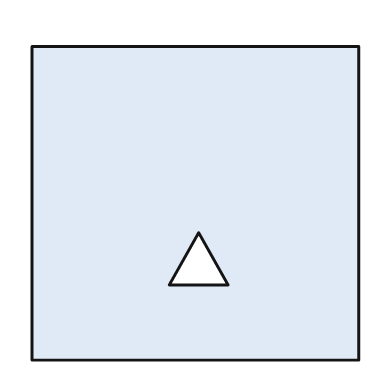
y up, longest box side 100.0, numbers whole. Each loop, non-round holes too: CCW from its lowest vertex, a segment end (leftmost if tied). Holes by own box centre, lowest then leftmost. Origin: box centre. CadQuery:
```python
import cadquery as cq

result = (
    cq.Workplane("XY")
    .moveTo(-50.0, -48.0)
    .lineTo(50.0, -48.0)
    .lineTo(50.0, 48.0)
    .lineTo(-50.0, 48.0)
    .close()
    .moveTo(-8.0, -25.0)
    .lineTo(10.0, -25.0)
    .lineTo(1.0, -9.0)
    .close()
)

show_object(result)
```